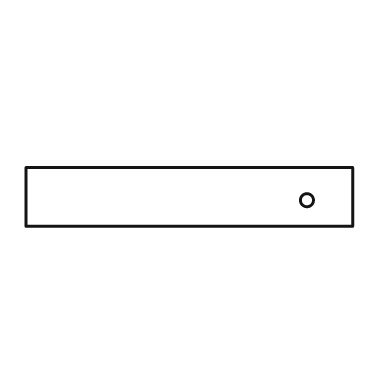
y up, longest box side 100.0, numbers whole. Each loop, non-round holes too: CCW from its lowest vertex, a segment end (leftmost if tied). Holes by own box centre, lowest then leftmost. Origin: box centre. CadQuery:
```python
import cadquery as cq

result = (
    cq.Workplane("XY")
    .moveTo(-50.0, -9.0)
    .lineTo(50.0, -9.0)
    .lineTo(50.0, 9.0)
    .lineTo(-50.0, 9.0)
    .close()
    .moveTo(36.0, -1.0)
    .circle(2.0)
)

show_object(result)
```